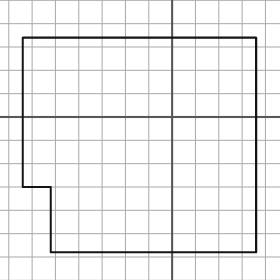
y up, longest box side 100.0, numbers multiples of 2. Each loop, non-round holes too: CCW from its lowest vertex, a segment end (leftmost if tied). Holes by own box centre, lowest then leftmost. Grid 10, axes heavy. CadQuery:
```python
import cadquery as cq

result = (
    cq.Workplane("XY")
    .moveTo(-52.0, -58.0)
    .lineTo(36.0, -58.0)
    .lineTo(36.0, 34.0)
    .lineTo(-64.0, 34.0)
    .lineTo(-64.0, -30.0)
    .lineTo(-52.0, -30.0)
    .close()
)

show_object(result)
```